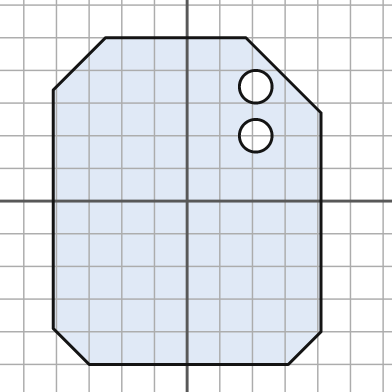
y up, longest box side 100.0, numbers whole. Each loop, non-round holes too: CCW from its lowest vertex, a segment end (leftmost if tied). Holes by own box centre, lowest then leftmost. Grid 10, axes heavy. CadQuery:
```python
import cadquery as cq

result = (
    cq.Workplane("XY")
    .moveTo(-30.0, -50.0)
    .lineTo(31.0, -50.0)
    .lineTo(41.0, -40.0)
    .lineTo(41.0, 27.0)
    .lineTo(18.0, 50.0)
    .lineTo(-25.0, 50.0)
    .lineTo(-41.0, 34.0)
    .lineTo(-41.0, -39.0)
    .close()
    .moveTo(21.0, 20.0)
    .circle(5.0)
    .moveTo(21.0, 35.0)
    .circle(5.0)
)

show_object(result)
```